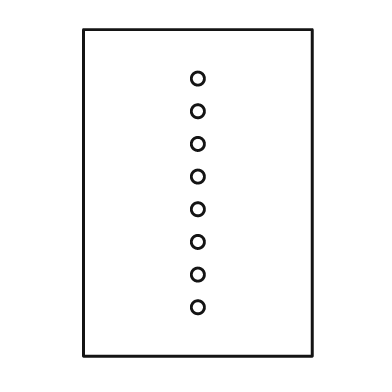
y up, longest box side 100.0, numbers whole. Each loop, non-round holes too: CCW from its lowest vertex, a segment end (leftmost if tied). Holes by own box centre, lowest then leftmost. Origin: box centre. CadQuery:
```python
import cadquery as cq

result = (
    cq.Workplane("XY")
    .moveTo(-35.0, -50.0)
    .lineTo(35.0, -50.0)
    .lineTo(35.0, 50.0)
    .lineTo(-35.0, 50.0)
    .close()
    .moveTo(0.0, -35.0)
    .circle(2.0)
    .moveTo(0.0, -25.0)
    .circle(2.0)
    .moveTo(0.0, -15.0)
    .circle(2.0)
    .moveTo(0.0, -5.0)
    .circle(2.0)
    .moveTo(0.0, 5.0)
    .circle(2.0)
    .moveTo(0.0, 15.0)
    .circle(2.0)
    .moveTo(0.0, 25.0)
    .circle(2.0)
    .moveTo(0.0, 35.0)
    .circle(2.0)
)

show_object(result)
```